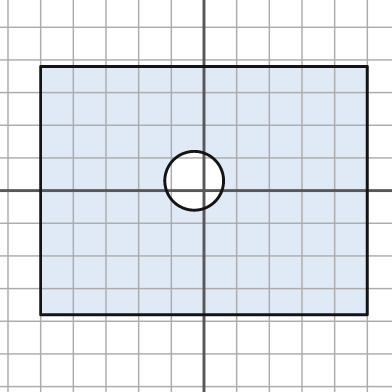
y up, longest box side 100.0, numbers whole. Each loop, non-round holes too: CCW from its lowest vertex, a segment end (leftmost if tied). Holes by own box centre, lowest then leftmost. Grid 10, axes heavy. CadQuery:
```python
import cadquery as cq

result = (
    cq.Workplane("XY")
    .moveTo(-50.0, -38.0)
    .lineTo(50.0, -38.0)
    .lineTo(50.0, 38.0)
    .lineTo(-50.0, 38.0)
    .close()
    .moveTo(-3.0, 3.0)
    .circle(9.0)
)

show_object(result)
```